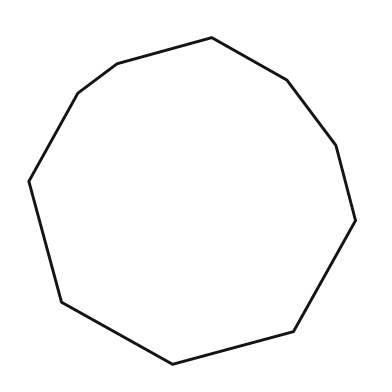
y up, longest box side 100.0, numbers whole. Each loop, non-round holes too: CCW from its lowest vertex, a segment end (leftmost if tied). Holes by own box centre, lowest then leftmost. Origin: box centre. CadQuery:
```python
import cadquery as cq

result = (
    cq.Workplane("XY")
    .moveTo(-6.0, -50.0)
    .lineTo(31.0, -40.0)
    .lineTo(50.0, -6.0)
    .lineTo(44.0, 17.0)
    .lineTo(29.0, 37.0)
    .lineTo(6.0, 50.0)
    .lineTo(-23.0, 42.0)
    .lineTo(-35.0, 33.0)
    .lineTo(-50.0, 6.0)
    .lineTo(-40.0, -31.0)
    .close()
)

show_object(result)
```